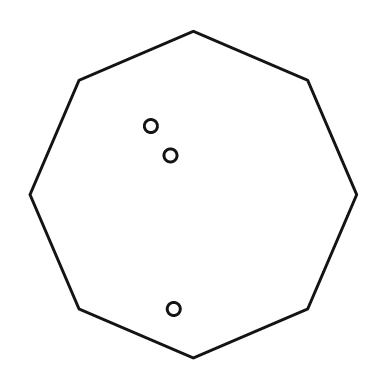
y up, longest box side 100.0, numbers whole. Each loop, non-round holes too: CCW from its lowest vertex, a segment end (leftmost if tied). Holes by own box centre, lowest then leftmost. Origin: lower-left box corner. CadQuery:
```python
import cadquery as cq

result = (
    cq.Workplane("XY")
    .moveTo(50.0, 0.0)
    .lineTo(85.0, 15.0)
    .lineTo(100.0, 50.0)
    .lineTo(85.0, 85.0)
    .lineTo(50.0, 100.0)
    .lineTo(15.0, 85.0)
    .lineTo(0.0, 50.0)
    .lineTo(15.0, 15.0)
    .close()
    .moveTo(44.0, 15.0)
    .circle(2.0)
    .moveTo(43.0, 62.0)
    .circle(2.0)
    .moveTo(37.0, 71.0)
    .circle(2.0)
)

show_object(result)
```